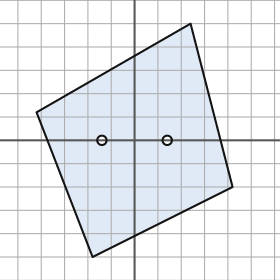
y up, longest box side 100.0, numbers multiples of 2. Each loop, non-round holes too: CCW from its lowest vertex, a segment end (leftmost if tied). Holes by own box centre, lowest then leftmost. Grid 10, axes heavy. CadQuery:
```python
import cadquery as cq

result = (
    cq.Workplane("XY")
    .moveTo(-18.0, -50.0)
    .lineTo(42.0, -20.0)
    .lineTo(24.0, 50.0)
    .lineTo(-42.0, 12.0)
    .close()
    .moveTo(-14.0, 0.0)
    .circle(2.0)
    .moveTo(14.0, 0.0)
    .circle(2.0)
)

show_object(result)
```